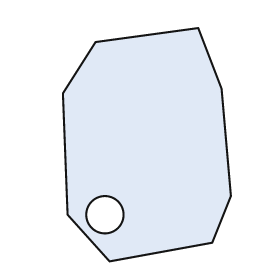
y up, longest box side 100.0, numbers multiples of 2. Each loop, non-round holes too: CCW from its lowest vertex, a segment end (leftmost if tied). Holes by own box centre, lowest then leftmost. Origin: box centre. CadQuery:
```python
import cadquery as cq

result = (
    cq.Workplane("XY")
    .moveTo(-16.0, -50.0)
    .lineTo(28.0, -42.0)
    .lineTo(36.0, -22.0)
    .lineTo(32.0, 24.0)
    .lineTo(22.0, 50.0)
    .lineTo(-22.0, 44.0)
    .lineTo(-36.0, 22.0)
    .lineTo(-34.0, -30.0)
    .close()
    .moveTo(-18.0, -30.0)
    .circle(8.0)
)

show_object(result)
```